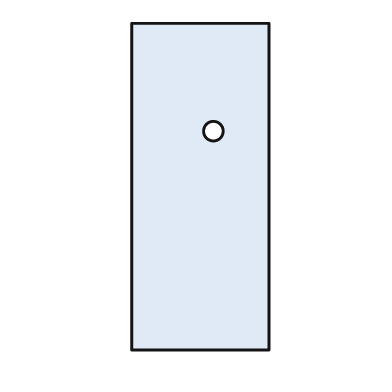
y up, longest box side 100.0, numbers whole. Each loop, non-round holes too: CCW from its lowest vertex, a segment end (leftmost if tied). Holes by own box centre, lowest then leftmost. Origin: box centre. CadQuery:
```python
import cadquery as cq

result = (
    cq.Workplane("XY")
    .moveTo(-21.0, -50.0)
    .lineTo(21.0, -50.0)
    .lineTo(21.0, 50.0)
    .lineTo(-21.0, 50.0)
    .close()
    .moveTo(4.0, 17.0)
    .circle(3.0)
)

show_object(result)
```